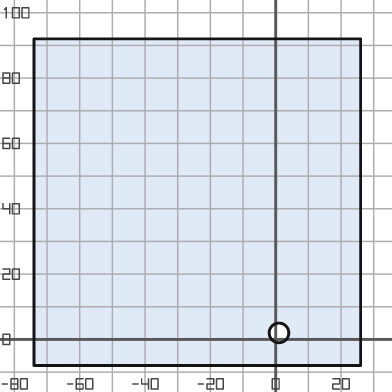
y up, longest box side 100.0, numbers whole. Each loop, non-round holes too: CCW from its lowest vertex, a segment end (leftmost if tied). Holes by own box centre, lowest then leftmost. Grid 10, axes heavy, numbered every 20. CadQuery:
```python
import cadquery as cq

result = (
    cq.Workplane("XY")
    .moveTo(-74.0, -8.0)
    .lineTo(26.0, -8.0)
    .lineTo(26.0, 92.0)
    .lineTo(-74.0, 92.0)
    .close()
    .moveTo(1.0, 2.0)
    .circle(3.0)
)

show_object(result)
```